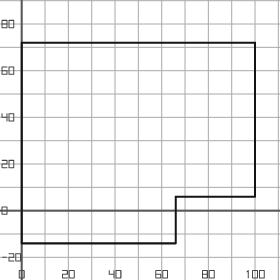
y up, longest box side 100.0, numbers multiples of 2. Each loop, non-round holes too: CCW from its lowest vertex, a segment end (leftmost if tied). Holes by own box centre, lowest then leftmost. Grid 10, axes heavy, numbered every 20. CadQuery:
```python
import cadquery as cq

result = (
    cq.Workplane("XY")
    .moveTo(0.0, -14.0)
    .lineTo(66.0, -14.0)
    .lineTo(66.0, 6.0)
    .lineTo(100.0, 6.0)
    .lineTo(100.0, 72.0)
    .lineTo(0.0, 72.0)
    .close()
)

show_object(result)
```